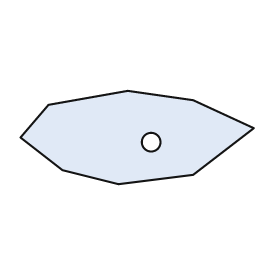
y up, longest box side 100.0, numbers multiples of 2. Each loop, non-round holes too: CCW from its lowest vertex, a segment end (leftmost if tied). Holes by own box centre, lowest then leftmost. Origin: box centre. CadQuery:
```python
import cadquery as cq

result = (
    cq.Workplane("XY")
    .moveTo(-8.0, -20.0)
    .lineTo(24.0, -16.0)
    .lineTo(50.0, 4.0)
    .lineTo(24.0, 16.0)
    .lineTo(-4.0, 20.0)
    .lineTo(-38.0, 14.0)
    .lineTo(-50.0, 0.0)
    .lineTo(-32.0, -14.0)
    .close()
    .moveTo(6.0, -2.0)
    .circle(4.0)
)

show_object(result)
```